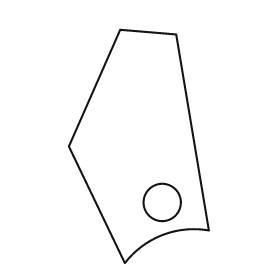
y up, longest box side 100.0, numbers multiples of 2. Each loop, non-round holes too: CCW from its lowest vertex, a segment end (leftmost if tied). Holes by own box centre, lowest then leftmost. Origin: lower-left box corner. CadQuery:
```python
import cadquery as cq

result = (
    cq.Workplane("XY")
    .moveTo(24.0, 0.0)
    .threePointArc((40.0, 12.0), (60.0, 14.0))
    .lineTo(46.0, 98.0)
    .lineTo(22.0, 100.0)
    .lineTo(0.0, 50.0)
    .close()
    .moveTo(40.0, 26.0)
    .circle(8.0)
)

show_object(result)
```